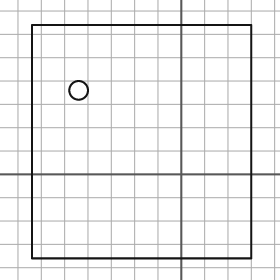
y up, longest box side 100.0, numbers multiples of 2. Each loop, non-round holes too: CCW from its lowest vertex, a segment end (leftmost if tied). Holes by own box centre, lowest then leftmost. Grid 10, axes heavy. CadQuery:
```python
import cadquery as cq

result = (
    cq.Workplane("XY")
    .moveTo(-64.0, -36.0)
    .lineTo(30.0, -36.0)
    .lineTo(30.0, 64.0)
    .lineTo(-64.0, 64.0)
    .close()
    .moveTo(-44.0, 36.0)
    .circle(4.0)
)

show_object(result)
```